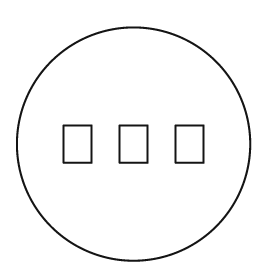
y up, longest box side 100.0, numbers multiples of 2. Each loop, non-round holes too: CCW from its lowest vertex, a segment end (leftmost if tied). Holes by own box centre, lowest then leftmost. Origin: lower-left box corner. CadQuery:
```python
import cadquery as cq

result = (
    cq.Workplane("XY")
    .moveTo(50.0, 50.0)
    .circle(50.0)
    .moveTo(20.0, 42.0)
    .lineTo(32.0, 42.0)
    .lineTo(32.0, 58.0)
    .lineTo(20.0, 58.0)
    .close()
    .moveTo(44.0, 42.0)
    .lineTo(56.0, 42.0)
    .lineTo(56.0, 58.0)
    .lineTo(44.0, 58.0)
    .close()
    .moveTo(68.0, 42.0)
    .lineTo(80.0, 42.0)
    .lineTo(80.0, 58.0)
    .lineTo(68.0, 58.0)
    .close()
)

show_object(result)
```